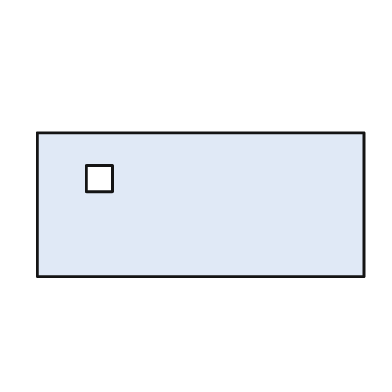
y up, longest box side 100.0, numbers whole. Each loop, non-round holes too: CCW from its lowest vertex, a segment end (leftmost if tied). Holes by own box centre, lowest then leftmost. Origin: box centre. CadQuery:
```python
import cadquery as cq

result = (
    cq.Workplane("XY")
    .moveTo(-50.0, -22.0)
    .lineTo(50.0, -22.0)
    .lineTo(50.0, 22.0)
    .lineTo(-50.0, 22.0)
    .close()
    .moveTo(-35.0, 4.0)
    .lineTo(-27.0, 4.0)
    .lineTo(-27.0, 12.0)
    .lineTo(-35.0, 12.0)
    .close()
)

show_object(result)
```